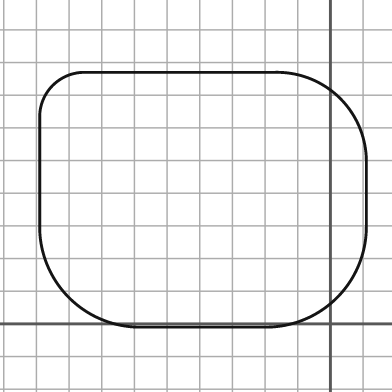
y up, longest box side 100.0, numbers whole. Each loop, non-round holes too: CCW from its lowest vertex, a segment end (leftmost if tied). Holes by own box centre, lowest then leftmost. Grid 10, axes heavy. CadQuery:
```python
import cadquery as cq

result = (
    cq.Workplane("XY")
    .moveTo(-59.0, -1.0)
    .lineTo(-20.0, -1.0)
    .threePointArc((2.0, 8.0), (11.0, 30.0))
    .lineTo(11.0, 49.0)
    .threePointArc((3.0, 69.0), (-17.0, 77.0))
    .lineTo(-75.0, 77.0)
    .threePointArc((-85.0, 73.0), (-89.0, 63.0))
    .lineTo(-89.0, 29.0)
    .threePointArc((-80.0, 8.0), (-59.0, -1.0))
    .close()
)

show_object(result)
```